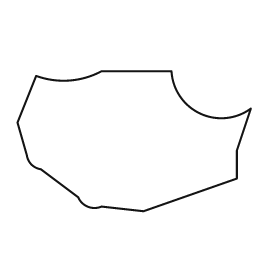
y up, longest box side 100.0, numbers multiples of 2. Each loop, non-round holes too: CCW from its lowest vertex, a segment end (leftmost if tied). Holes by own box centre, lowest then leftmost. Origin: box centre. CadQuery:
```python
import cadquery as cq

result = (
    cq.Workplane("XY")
    .moveTo(4.0, -30.0)
    .lineTo(44.0, -16.0)
    .lineTo(44.0, -4.0)
    .lineTo(50.0, 14.0)
    .threePointArc((28.0, 12.0), (16.0, 30.0))
    .lineTo(-14.0, 30.0)
    .threePointArc((-28.0, 26.0), (-42.0, 28.0))
    .lineTo(-50.0, 8.0)
    .lineTo(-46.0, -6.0)
    .threePointArc((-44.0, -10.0), (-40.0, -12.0))
    .lineTo(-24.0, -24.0)
    .threePointArc((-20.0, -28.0), (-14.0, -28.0))
    .close()
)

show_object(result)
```